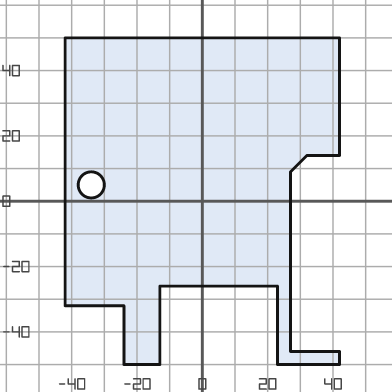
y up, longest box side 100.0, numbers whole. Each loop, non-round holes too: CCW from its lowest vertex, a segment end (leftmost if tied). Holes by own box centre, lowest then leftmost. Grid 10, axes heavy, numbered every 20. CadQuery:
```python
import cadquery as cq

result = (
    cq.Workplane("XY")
    .moveTo(-24.0, -50.0)
    .lineTo(-13.0, -50.0)
    .lineTo(-13.0, -26.0)
    .lineTo(23.0, -26.0)
    .lineTo(23.0, -50.0)
    .lineTo(42.0, -50.0)
    .lineTo(42.0, -46.0)
    .lineTo(27.0, -46.0)
    .lineTo(27.0, 9.0)
    .lineTo(32.0, 14.0)
    .lineTo(42.0, 14.0)
    .lineTo(42.0, 50.0)
    .lineTo(-42.0, 50.0)
    .lineTo(-42.0, -32.0)
    .lineTo(-24.0, -32.0)
    .close()
    .moveTo(-34.0, 5.0)
    .circle(4.0)
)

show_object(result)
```